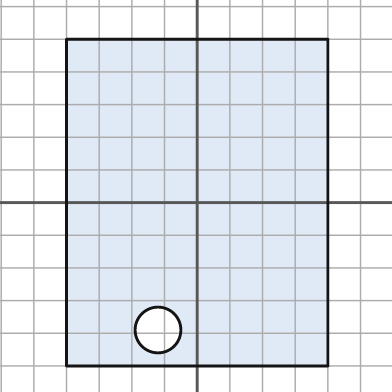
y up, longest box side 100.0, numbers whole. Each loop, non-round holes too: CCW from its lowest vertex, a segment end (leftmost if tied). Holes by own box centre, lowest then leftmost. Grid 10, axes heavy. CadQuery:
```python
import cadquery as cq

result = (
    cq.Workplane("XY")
    .moveTo(-40.0, -50.0)
    .lineTo(40.0, -50.0)
    .lineTo(40.0, 50.0)
    .lineTo(-40.0, 50.0)
    .close()
    .moveTo(-12.0, -39.0)
    .circle(7.0)
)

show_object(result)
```